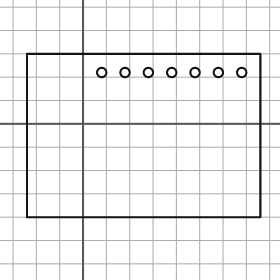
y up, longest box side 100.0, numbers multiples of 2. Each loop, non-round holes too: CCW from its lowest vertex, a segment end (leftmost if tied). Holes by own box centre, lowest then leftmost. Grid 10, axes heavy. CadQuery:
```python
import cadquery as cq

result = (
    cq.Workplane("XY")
    .moveTo(-24.0, -40.0)
    .lineTo(76.0, -40.0)
    .lineTo(76.0, 30.0)
    .lineTo(-24.0, 30.0)
    .close()
    .moveTo(8.0, 22.0)
    .circle(2.0)
    .moveTo(18.0, 22.0)
    .circle(2.0)
    .moveTo(28.0, 22.0)
    .circle(2.0)
    .moveTo(38.0, 22.0)
    .circle(2.0)
    .moveTo(48.0, 22.0)
    .circle(2.0)
    .moveTo(58.0, 22.0)
    .circle(2.0)
    .moveTo(68.0, 22.0)
    .circle(2.0)
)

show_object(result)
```